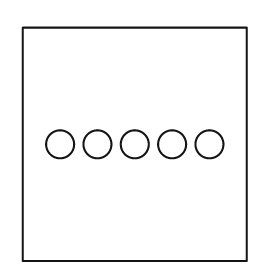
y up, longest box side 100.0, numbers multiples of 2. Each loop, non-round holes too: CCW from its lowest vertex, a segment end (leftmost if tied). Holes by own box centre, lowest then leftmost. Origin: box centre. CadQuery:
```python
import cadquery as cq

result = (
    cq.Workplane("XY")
    .moveTo(-48.0, -50.0)
    .lineTo(48.0, -50.0)
    .lineTo(48.0, 50.0)
    .lineTo(-48.0, 50.0)
    .close()
    .moveTo(-32.0, 0.0)
    .circle(6.0)
    .moveTo(-16.0, 0.0)
    .circle(6.0)
    .moveTo(0.0, 0.0)
    .circle(6.0)
    .moveTo(16.0, 0.0)
    .circle(6.0)
    .moveTo(32.0, 0.0)
    .circle(6.0)
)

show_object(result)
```